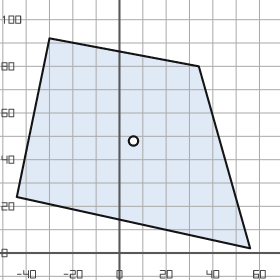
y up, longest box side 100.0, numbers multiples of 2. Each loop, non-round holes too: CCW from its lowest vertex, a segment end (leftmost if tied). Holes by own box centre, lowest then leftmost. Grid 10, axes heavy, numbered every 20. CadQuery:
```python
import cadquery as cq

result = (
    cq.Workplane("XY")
    .moveTo(56.0, 2.0)
    .lineTo(34.0, 80.0)
    .lineTo(-30.0, 92.0)
    .lineTo(-44.0, 24.0)
    .close()
    .moveTo(6.0, 48.0)
    .circle(2.0)
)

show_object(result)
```